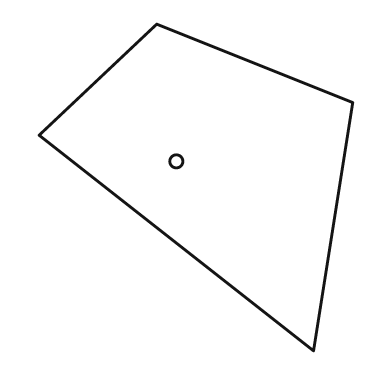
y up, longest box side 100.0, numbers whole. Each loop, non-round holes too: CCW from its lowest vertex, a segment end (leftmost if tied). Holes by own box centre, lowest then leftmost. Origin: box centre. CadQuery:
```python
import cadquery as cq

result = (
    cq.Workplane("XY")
    .moveTo(36.0, -50.0)
    .lineTo(48.0, 26.0)
    .lineTo(-12.0, 50.0)
    .lineTo(-48.0, 16.0)
    .close()
    .moveTo(-6.0, 8.0)
    .circle(2.0)
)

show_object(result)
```